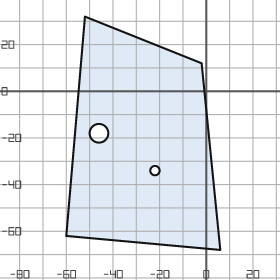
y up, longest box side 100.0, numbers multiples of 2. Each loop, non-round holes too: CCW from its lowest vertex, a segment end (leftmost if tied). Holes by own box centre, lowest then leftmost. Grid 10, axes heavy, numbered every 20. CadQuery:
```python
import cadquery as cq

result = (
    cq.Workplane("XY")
    .moveTo(6.0, -68.0)
    .lineTo(-2.0, 12.0)
    .lineTo(-52.0, 32.0)
    .lineTo(-60.0, -62.0)
    .close()
    .moveTo(-22.0, -34.0)
    .circle(2.0)
    .moveTo(-46.0, -18.0)
    .circle(4.0)
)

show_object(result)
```